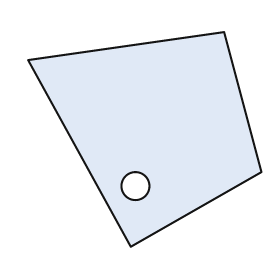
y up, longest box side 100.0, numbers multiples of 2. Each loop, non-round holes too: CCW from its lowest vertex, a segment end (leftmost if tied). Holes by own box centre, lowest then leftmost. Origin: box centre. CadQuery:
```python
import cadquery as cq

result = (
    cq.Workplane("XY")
    .moveTo(-6.0, -46.0)
    .lineTo(50.0, -14.0)
    .lineTo(34.0, 46.0)
    .lineTo(-50.0, 34.0)
    .close()
    .moveTo(-4.0, -20.0)
    .circle(6.0)
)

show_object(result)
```